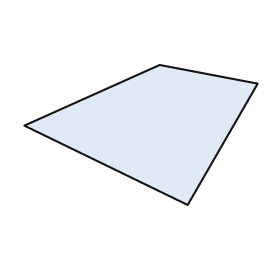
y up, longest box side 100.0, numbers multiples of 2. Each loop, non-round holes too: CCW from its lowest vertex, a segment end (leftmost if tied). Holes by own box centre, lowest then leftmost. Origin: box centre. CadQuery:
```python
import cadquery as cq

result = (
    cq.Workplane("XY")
    .moveTo(20.0, -30.0)
    .lineTo(50.0, 22.0)
    .lineTo(8.0, 30.0)
    .lineTo(-50.0, 4.0)
    .close()
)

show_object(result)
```